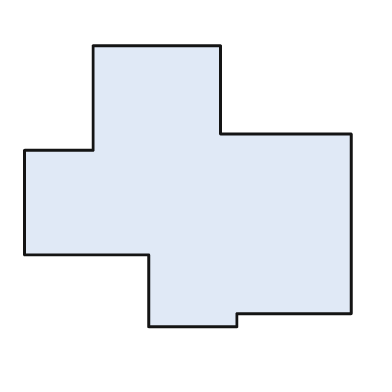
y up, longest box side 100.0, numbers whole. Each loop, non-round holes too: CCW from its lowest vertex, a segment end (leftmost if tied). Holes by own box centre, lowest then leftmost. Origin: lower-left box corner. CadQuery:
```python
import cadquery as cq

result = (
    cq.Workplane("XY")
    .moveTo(38.0, 0.0)
    .lineTo(65.0, 0.0)
    .lineTo(65.0, 4.0)
    .lineTo(100.0, 4.0)
    .lineTo(100.0, 59.0)
    .lineTo(60.0, 59.0)
    .lineTo(60.0, 86.0)
    .lineTo(21.0, 86.0)
    .lineTo(21.0, 54.0)
    .lineTo(0.0, 54.0)
    .lineTo(0.0, 22.0)
    .lineTo(38.0, 22.0)
    .close()
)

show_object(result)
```